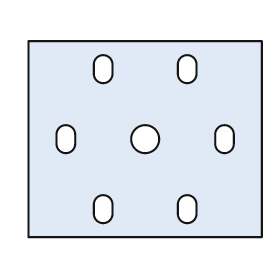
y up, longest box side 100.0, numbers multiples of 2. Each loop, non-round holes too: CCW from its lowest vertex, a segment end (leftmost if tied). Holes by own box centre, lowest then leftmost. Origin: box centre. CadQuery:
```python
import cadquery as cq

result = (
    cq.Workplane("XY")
    .moveTo(-50.0, -42.0)
    .lineTo(50.0, -42.0)
    .lineTo(50.0, 42.0)
    .lineTo(-50.0, 42.0)
    .close()
    .moveTo(-22.0, -32.0)
    .threePointArc((-18.0, -36.0), (-14.0, -32.0))
    .lineTo(-14.0, -28.0)
    .threePointArc((-18.0, -24.0), (-22.0, -28.0))
    .close()
    .moveTo(14.0, -32.0)
    .threePointArc((18.0, -36.0), (22.0, -32.0))
    .lineTo(22.0, -28.0)
    .threePointArc((18.0, -24.0), (14.0, -28.0))
    .close()
    .moveTo(-38.0, -2.0)
    .threePointArc((-34.0, -6.0), (-30.0, -2.0))
    .lineTo(-30.0, 2.0)
    .threePointArc((-34.0, 6.0), (-38.0, 2.0))
    .close()
    .moveTo(0.0, 0.0)
    .circle(6.0)
    .moveTo(30.0, -2.0)
    .threePointArc((34.0, -6.0), (38.0, -2.0))
    .lineTo(38.0, 2.0)
    .threePointArc((34.0, 6.0), (30.0, 2.0))
    .close()
    .moveTo(-22.0, 28.0)
    .threePointArc((-18.0, 24.0), (-14.0, 28.0))
    .lineTo(-14.0, 32.0)
    .threePointArc((-18.0, 36.0), (-22.0, 32.0))
    .close()
    .moveTo(14.0, 28.0)
    .threePointArc((18.0, 24.0), (22.0, 28.0))
    .lineTo(22.0, 32.0)
    .threePointArc((18.0, 36.0), (14.0, 32.0))
    .close()
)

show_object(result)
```